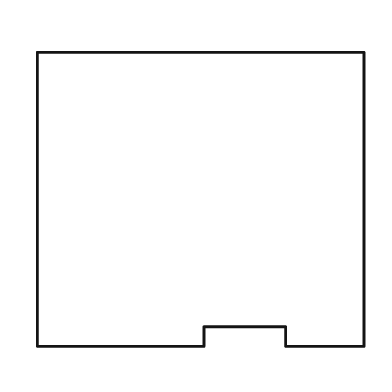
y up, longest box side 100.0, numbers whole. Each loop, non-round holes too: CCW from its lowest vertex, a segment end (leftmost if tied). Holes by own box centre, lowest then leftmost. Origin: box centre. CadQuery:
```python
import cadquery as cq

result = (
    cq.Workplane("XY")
    .moveTo(-50.0, -45.0)
    .lineTo(1.0, -45.0)
    .lineTo(1.0, -39.0)
    .lineTo(26.0, -39.0)
    .lineTo(26.0, -45.0)
    .lineTo(50.0, -45.0)
    .lineTo(50.0, 45.0)
    .lineTo(-50.0, 45.0)
    .close()
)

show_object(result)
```